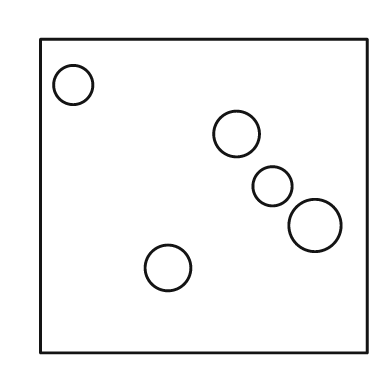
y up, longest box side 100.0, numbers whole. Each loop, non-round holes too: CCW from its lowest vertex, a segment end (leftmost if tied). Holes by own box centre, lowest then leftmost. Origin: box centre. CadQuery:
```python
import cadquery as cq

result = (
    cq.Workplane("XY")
    .moveTo(-50.0, -48.0)
    .lineTo(50.0, -48.0)
    .lineTo(50.0, 48.0)
    .lineTo(-50.0, 48.0)
    .close()
    .moveTo(-11.0, -22.0)
    .circle(7.0)
    .moveTo(34.0, -9.0)
    .circle(8.0)
    .moveTo(21.0, 3.0)
    .circle(6.0)
    .moveTo(10.0, 19.0)
    .circle(7.0)
    .moveTo(-40.0, 34.0)
    .circle(6.0)
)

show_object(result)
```